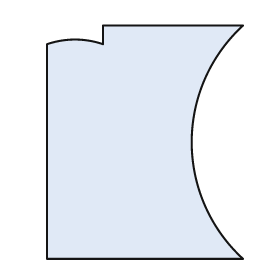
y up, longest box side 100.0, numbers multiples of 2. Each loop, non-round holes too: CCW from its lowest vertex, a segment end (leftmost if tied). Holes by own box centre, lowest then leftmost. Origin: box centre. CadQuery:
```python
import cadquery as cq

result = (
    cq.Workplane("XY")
    .moveTo(-42.0, -50.0)
    .lineTo(42.0, -50.0)
    .threePointArc((20.0, 0.0), (42.0, 50.0))
    .lineTo(-18.0, 50.0)
    .lineTo(-18.0, 42.0)
    .threePointArc((-30.0, 44.0), (-42.0, 42.0))
    .close()
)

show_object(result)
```